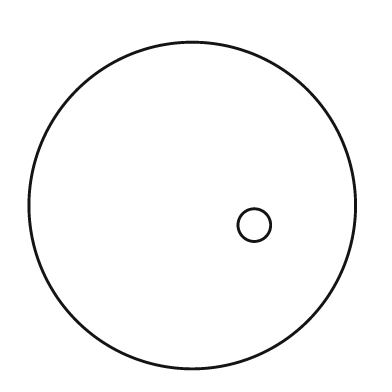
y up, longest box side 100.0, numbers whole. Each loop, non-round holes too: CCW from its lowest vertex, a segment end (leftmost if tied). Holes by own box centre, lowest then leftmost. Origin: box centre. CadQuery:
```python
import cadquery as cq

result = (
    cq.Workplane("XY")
    .moveTo(0.0, 0.0)
    .circle(50.0)
    .moveTo(19.0, -6.0)
    .circle(5.0)
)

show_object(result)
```